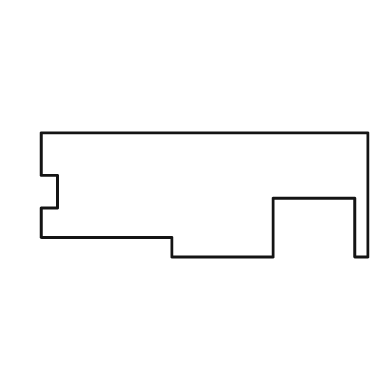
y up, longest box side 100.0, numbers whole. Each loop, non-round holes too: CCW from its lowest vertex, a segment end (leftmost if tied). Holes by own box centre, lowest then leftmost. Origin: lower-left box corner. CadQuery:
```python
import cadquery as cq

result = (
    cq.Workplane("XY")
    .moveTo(40.0, 0.0)
    .lineTo(71.0, 0.0)
    .lineTo(71.0, 18.0)
    .lineTo(96.0, 18.0)
    .lineTo(96.0, 0.0)
    .lineTo(100.0, 0.0)
    .lineTo(100.0, 38.0)
    .lineTo(0.0, 38.0)
    .lineTo(0.0, 25.0)
    .lineTo(5.0, 25.0)
    .lineTo(5.0, 15.0)
    .lineTo(0.0, 15.0)
    .lineTo(0.0, 6.0)
    .lineTo(40.0, 6.0)
    .close()
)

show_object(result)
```